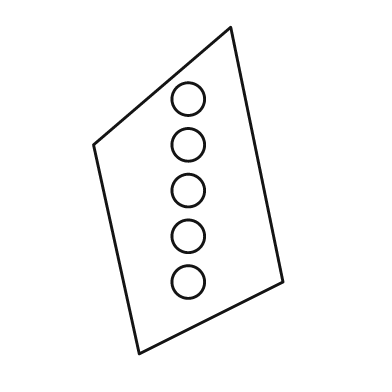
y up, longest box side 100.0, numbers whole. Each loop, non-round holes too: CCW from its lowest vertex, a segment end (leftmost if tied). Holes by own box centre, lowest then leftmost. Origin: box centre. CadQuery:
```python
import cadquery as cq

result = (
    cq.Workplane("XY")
    .moveTo(-15.0, -50.0)
    .lineTo(29.0, -28.0)
    .lineTo(13.0, 50.0)
    .lineTo(-29.0, 14.0)
    .close()
    .moveTo(0.0, -28.0)
    .circle(5.0)
    .moveTo(0.0, -14.0)
    .circle(5.0)
    .moveTo(0.0, 0.0)
    .circle(5.0)
    .moveTo(0.0, 14.0)
    .circle(5.0)
    .moveTo(0.0, 28.0)
    .circle(5.0)
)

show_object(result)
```